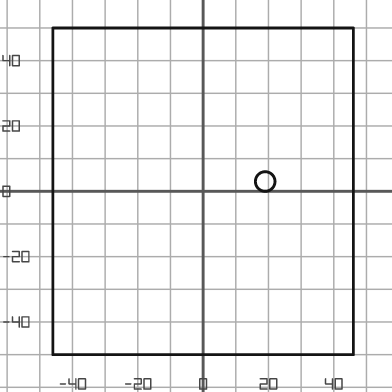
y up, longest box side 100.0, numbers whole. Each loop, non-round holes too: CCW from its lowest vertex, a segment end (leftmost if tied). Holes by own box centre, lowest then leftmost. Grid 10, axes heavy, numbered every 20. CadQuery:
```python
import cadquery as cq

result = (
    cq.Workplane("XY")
    .moveTo(-46.0, -50.0)
    .lineTo(46.0, -50.0)
    .lineTo(46.0, 50.0)
    .lineTo(-46.0, 50.0)
    .close()
    .moveTo(19.0, 3.0)
    .circle(3.0)
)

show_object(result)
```